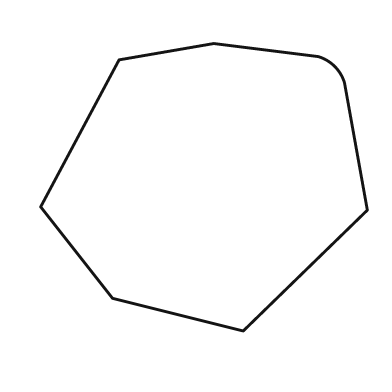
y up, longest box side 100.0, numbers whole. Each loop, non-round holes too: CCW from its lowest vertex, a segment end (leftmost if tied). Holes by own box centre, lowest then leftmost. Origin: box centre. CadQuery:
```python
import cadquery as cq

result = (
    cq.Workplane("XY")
    .moveTo(12.0, -44.0)
    .lineTo(50.0, -7.0)
    .lineTo(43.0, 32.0)
    .threePointArc((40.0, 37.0), (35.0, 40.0))
    .lineTo(3.0, 44.0)
    .lineTo(-26.0, 39.0)
    .lineTo(-50.0, -6.0)
    .lineTo(-28.0, -34.0)
    .close()
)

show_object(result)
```